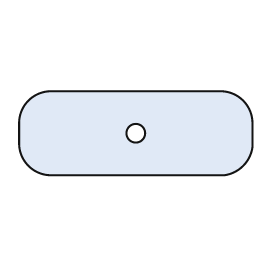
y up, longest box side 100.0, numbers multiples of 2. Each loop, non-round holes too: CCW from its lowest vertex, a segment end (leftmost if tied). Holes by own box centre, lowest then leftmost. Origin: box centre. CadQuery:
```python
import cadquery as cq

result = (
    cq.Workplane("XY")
    .moveTo(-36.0, -18.0)
    .lineTo(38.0, -18.0)
    .threePointArc((46.0, -14.0), (50.0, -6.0))
    .lineTo(50.0, 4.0)
    .threePointArc((46.0, 14.0), (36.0, 18.0))
    .lineTo(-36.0, 18.0)
    .threePointArc((-46.0, 14.0), (-50.0, 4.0))
    .lineTo(-50.0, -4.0)
    .threePointArc((-46.0, -14.0), (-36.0, -18.0))
    .close()
    .moveTo(0.0, 0.0)
    .circle(4.0)
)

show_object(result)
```